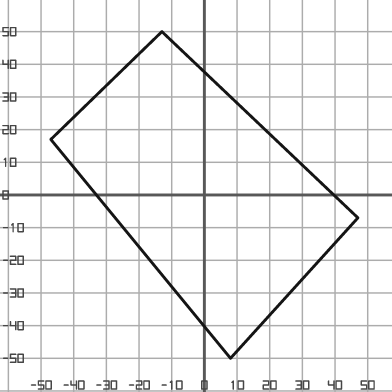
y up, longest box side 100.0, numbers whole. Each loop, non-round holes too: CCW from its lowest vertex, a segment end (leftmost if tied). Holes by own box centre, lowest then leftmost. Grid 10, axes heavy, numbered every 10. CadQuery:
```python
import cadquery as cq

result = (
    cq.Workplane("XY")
    .moveTo(8.0, -50.0)
    .lineTo(47.0, -7.0)
    .lineTo(-13.0, 50.0)
    .lineTo(-47.0, 17.0)
    .close()
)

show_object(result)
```